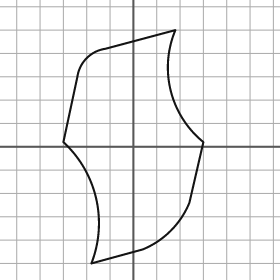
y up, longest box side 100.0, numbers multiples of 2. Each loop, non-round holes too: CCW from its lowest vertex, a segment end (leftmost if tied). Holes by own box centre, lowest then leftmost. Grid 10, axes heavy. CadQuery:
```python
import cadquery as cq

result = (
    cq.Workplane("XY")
    .moveTo(-18.0, -50.0)
    .lineTo(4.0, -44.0)
    .threePointArc((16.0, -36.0), (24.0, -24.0))
    .lineTo(30.0, 2.0)
    .threePointArc((16.0, 24.0), (18.0, 50.0))
    .lineTo(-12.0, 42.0)
    .threePointArc((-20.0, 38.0), (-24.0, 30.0))
    .lineTo(-30.0, 2.0)
    .threePointArc((-16.0, -22.0), (-18.0, -50.0))
    .close()
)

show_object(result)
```